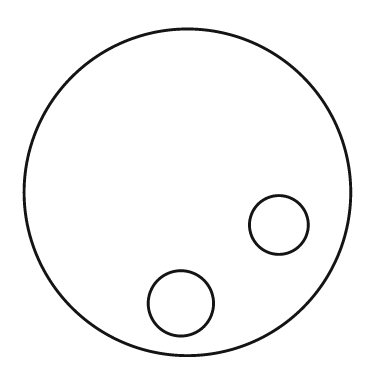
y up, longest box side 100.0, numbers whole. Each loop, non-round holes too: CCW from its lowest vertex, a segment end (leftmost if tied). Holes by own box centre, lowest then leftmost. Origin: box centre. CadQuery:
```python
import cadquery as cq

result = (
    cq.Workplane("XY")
    .moveTo(0.0, 0.0)
    .circle(50.0)
    .moveTo(-2.0, -34.0)
    .circle(10.0)
    .moveTo(28.0, -10.0)
    .circle(9.0)
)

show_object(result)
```